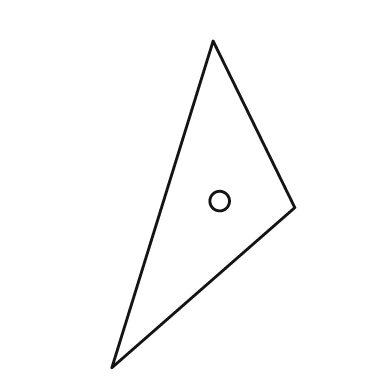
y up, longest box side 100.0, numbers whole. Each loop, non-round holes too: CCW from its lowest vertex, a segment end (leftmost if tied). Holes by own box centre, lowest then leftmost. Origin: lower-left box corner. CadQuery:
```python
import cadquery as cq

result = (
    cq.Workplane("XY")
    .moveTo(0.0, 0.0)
    .lineTo(56.0, 49.0)
    .lineTo(31.0, 100.0)
    .close()
    .moveTo(33.0, 51.0)
    .circle(3.0)
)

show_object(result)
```